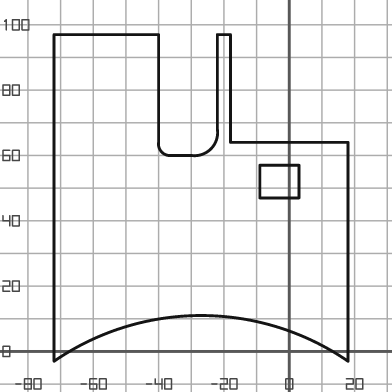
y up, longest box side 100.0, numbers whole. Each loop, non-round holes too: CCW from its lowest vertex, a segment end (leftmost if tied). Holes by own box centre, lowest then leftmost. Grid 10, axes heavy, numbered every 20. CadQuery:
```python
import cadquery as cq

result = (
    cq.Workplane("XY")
    .moveTo(-72.0, -3.0)
    .threePointArc((-27.0, 11.0), (18.0, -3.0))
    .lineTo(18.0, 64.0)
    .lineTo(-18.0, 64.0)
    .lineTo(-18.0, 97.0)
    .lineTo(-22.0, 97.0)
    .lineTo(-22.0, 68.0)
    .threePointArc((-24.0, 62.0), (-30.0, 60.0))
    .lineTo(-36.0, 60.0)
    .threePointArc((-39.0, 61.0), (-40.0, 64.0))
    .lineTo(-40.0, 97.0)
    .lineTo(-72.0, 97.0)
    .close()
    .moveTo(-9.0, 47.0)
    .lineTo(3.0, 47.0)
    .lineTo(3.0, 57.0)
    .lineTo(-9.0, 57.0)
    .close()
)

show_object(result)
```